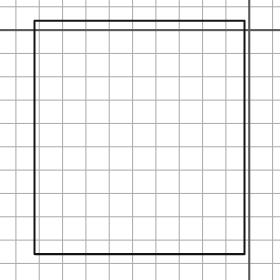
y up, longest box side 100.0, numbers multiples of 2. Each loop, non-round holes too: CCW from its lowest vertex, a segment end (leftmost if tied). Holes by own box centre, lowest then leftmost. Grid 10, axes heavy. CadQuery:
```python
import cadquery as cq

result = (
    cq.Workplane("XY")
    .moveTo(-92.0, -96.0)
    .lineTo(-2.0, -96.0)
    .lineTo(-2.0, 4.0)
    .lineTo(-92.0, 4.0)
    .close()
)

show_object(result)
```